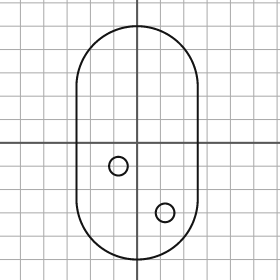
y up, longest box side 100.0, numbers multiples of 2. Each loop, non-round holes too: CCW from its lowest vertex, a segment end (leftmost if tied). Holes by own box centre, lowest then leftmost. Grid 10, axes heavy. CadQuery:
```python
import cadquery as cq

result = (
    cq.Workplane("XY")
    .moveTo(-26.0, -24.0)
    .threePointArc((0.0, -50.0), (26.0, -24.0))
    .lineTo(26.0, 24.0)
    .threePointArc((0.0, 50.0), (-26.0, 24.0))
    .close()
    .moveTo(12.0, -30.0)
    .circle(4.0)
    .moveTo(-8.0, -10.0)
    .circle(4.0)
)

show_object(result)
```